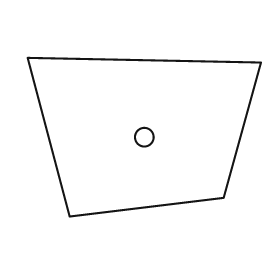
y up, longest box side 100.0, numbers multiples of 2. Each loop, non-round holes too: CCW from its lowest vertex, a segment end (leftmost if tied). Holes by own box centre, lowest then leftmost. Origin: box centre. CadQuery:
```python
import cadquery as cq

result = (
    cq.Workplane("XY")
    .moveTo(-32.0, -34.0)
    .lineTo(34.0, -26.0)
    .lineTo(50.0, 32.0)
    .lineTo(-50.0, 34.0)
    .close()
    .moveTo(0.0, 0.0)
    .circle(4.0)
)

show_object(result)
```